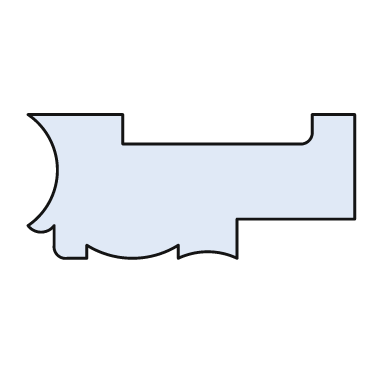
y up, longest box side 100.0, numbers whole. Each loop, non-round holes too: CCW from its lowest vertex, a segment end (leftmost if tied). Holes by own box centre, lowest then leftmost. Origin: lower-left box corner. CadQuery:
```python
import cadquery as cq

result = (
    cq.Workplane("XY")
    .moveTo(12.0, 0.0)
    .lineTo(18.0, 0.0)
    .lineTo(18.0, 4.0)
    .threePointArc((32.0, 0.0), (46.0, 4.0))
    .lineTo(46.0, 0.0)
    .threePointArc((55.0, 2.0), (64.0, 0.0))
    .lineTo(64.0, 12.0)
    .lineTo(100.0, 12.0)
    .lineTo(100.0, 44.0)
    .lineTo(87.0, 44.0)
    .lineTo(87.0, 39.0)
    .threePointArc((86.0, 36.0), (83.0, 35.0))
    .lineTo(29.0, 35.0)
    .lineTo(29.0, 44.0)
    .lineTo(0.0, 44.0)
    .threePointArc((9.0, 27.0), (0.0, 10.0))
    .threePointArc((4.0, 8.0), (8.0, 10.0))
    .lineTo(8.0, 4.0)
    .threePointArc((9.0, 1.0), (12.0, 0.0))
    .close()
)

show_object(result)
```